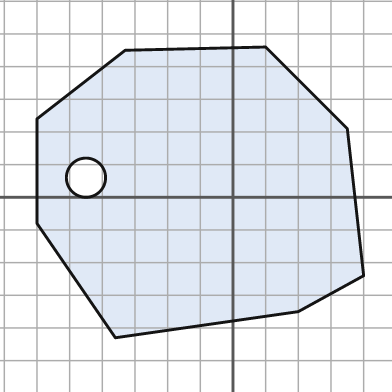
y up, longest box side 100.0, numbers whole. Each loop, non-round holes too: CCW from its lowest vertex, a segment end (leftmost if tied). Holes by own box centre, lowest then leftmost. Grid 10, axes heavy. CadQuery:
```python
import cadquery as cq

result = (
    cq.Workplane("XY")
    .moveTo(-36.0, -43.0)
    .lineTo(20.0, -35.0)
    .lineTo(40.0, -24.0)
    .lineTo(35.0, 21.0)
    .lineTo(10.0, 46.0)
    .lineTo(-33.0, 45.0)
    .lineTo(-60.0, 24.0)
    .lineTo(-60.0, -8.0)
    .close()
    .moveTo(-45.0, 6.0)
    .circle(6.0)
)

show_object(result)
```